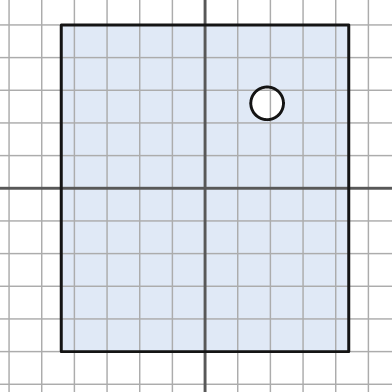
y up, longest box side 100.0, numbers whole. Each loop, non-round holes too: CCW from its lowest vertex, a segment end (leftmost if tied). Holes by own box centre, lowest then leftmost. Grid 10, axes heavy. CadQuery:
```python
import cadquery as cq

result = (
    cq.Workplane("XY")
    .moveTo(-44.0, -50.0)
    .lineTo(44.0, -50.0)
    .lineTo(44.0, 50.0)
    .lineTo(-44.0, 50.0)
    .close()
    .moveTo(19.0, 26.0)
    .circle(5.0)
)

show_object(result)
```